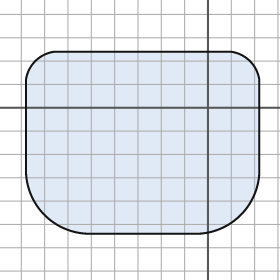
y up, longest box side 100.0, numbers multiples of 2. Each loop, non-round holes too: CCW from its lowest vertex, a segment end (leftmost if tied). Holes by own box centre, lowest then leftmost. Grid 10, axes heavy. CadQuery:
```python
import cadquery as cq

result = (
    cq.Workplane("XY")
    .moveTo(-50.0, -54.0)
    .lineTo(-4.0, -54.0)
    .threePointArc((14.0, -46.0), (22.0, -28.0))
    .lineTo(22.0, 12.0)
    .threePointArc((18.0, 20.0), (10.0, 24.0))
    .lineTo(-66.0, 24.0)
    .threePointArc((-74.0, 20.0), (-78.0, 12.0))
    .lineTo(-78.0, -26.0)
    .threePointArc((-70.0, -46.0), (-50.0, -54.0))
    .close()
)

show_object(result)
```